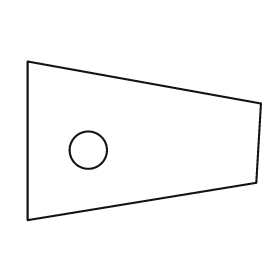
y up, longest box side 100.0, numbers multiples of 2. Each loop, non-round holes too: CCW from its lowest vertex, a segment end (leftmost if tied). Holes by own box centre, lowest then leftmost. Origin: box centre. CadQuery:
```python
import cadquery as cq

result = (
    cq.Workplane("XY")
    .moveTo(-50.0, -34.0)
    .lineTo(48.0, -18.0)
    .lineTo(50.0, 16.0)
    .lineTo(-50.0, 34.0)
    .close()
    .moveTo(-24.0, -4.0)
    .circle(8.0)
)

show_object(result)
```